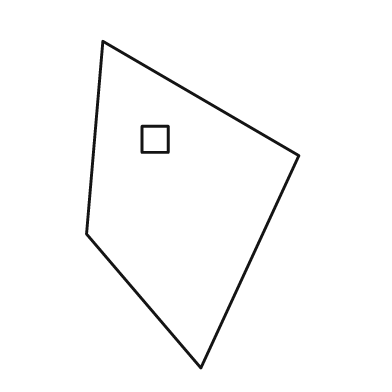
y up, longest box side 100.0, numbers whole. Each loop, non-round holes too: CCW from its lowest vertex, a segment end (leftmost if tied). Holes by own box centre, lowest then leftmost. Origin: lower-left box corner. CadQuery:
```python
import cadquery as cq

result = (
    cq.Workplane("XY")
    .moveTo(35.0, 0.0)
    .lineTo(65.0, 65.0)
    .lineTo(5.0, 100.0)
    .lineTo(0.0, 41.0)
    .close()
    .moveTo(17.0, 66.0)
    .lineTo(25.0, 66.0)
    .lineTo(25.0, 74.0)
    .lineTo(17.0, 74.0)
    .close()
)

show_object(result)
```